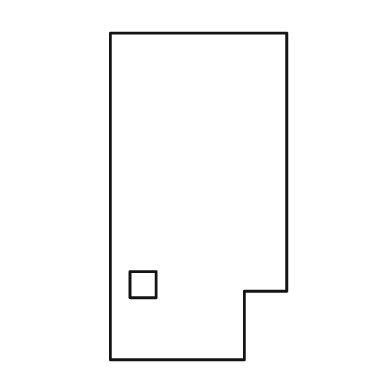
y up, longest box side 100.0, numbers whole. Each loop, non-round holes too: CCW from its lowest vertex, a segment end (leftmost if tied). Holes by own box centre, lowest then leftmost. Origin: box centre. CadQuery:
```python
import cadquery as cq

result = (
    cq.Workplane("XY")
    .moveTo(-27.0, -50.0)
    .lineTo(14.0, -50.0)
    .lineTo(14.0, -29.0)
    .lineTo(27.0, -29.0)
    .lineTo(27.0, 50.0)
    .lineTo(-27.0, 50.0)
    .close()
    .moveTo(-21.0, -31.0)
    .lineTo(-13.0, -31.0)
    .lineTo(-13.0, -23.0)
    .lineTo(-21.0, -23.0)
    .close()
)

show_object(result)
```